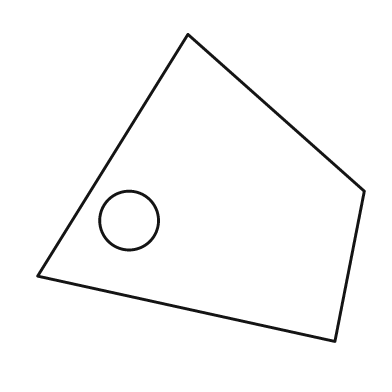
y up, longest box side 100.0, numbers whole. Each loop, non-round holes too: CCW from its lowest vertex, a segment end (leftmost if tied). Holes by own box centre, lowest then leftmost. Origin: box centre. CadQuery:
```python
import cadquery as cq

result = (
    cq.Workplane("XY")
    .moveTo(41.0, -47.0)
    .lineTo(50.0, -1.0)
    .lineTo(-4.0, 47.0)
    .lineTo(-50.0, -27.0)
    .close()
    .moveTo(-22.0, -10.0)
    .circle(9.0)
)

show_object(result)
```